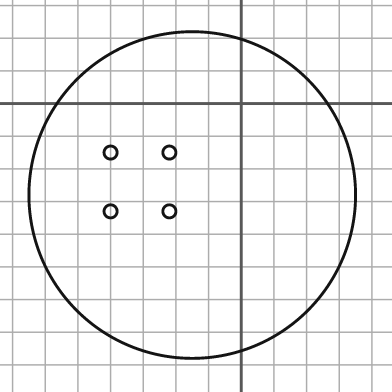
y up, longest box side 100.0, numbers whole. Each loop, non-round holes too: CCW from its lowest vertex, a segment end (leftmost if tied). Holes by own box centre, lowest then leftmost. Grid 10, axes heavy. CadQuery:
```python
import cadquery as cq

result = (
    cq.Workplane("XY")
    .moveTo(-15.0, -28.0)
    .circle(50.0)
    .moveTo(-40.0, -33.0)
    .circle(2.0)
    .moveTo(-22.0, -33.0)
    .circle(2.0)
    .moveTo(-40.0, -15.0)
    .circle(2.0)
    .moveTo(-22.0, -15.0)
    .circle(2.0)
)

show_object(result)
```